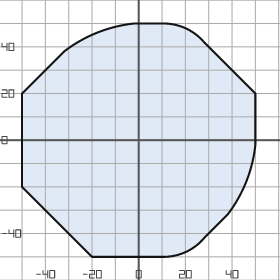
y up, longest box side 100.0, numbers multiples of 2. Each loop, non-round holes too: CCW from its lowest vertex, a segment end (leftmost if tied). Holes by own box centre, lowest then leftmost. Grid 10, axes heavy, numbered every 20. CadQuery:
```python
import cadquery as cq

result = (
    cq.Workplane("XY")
    .moveTo(-20.0, -50.0)
    .lineTo(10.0, -50.0)
    .threePointArc((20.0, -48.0), (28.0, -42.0))
    .lineTo(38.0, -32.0)
    .threePointArc((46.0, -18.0), (50.0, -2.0))
    .lineTo(50.0, 20.0)
    .lineTo(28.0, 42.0)
    .threePointArc((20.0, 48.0), (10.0, 50.0))
    .lineTo(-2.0, 50.0)
    .threePointArc((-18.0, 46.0), (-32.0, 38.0))
    .lineTo(-50.0, 20.0)
    .lineTo(-50.0, -20.0)
    .close()
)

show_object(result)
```